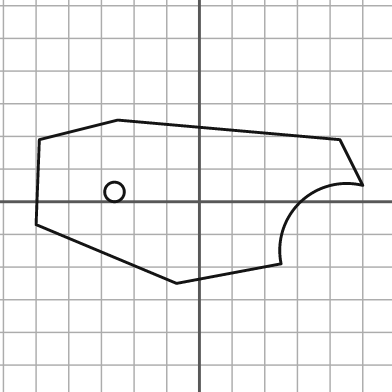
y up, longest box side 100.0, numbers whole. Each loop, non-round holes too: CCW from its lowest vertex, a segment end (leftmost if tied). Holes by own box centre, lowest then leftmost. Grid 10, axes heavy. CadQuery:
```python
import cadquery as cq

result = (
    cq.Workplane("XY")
    .moveTo(-7.0, -25.0)
    .lineTo(25.0, -19.0)
    .threePointArc((31.0, 0.0), (50.0, 5.0))
    .lineTo(43.0, 19.0)
    .lineTo(-25.0, 25.0)
    .lineTo(-49.0, 19.0)
    .lineTo(-50.0, -7.0)
    .close()
    .moveTo(-26.0, 3.0)
    .circle(3.0)
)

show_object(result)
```